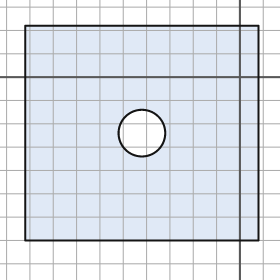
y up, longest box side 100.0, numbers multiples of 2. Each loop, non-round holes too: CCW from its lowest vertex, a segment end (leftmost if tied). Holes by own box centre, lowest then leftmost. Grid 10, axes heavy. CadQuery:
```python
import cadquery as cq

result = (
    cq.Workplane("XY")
    .moveTo(-92.0, -70.0)
    .lineTo(8.0, -70.0)
    .lineTo(8.0, 22.0)
    .lineTo(-92.0, 22.0)
    .close()
    .moveTo(-42.0, -24.0)
    .circle(10.0)
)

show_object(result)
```